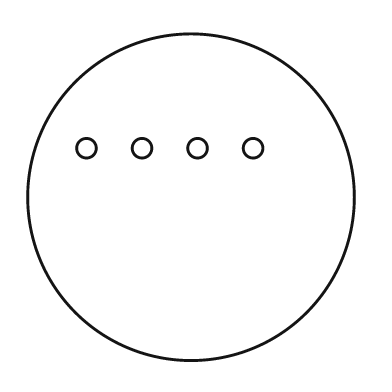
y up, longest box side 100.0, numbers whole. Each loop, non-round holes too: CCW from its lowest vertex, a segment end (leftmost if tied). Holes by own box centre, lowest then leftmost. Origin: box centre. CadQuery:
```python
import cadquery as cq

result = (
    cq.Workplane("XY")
    .moveTo(0.0, 0.0)
    .circle(50.0)
    .moveTo(-32.0, 15.0)
    .circle(3.0)
    .moveTo(-15.0, 15.0)
    .circle(3.0)
    .moveTo(2.0, 15.0)
    .circle(3.0)
    .moveTo(19.0, 15.0)
    .circle(3.0)
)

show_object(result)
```